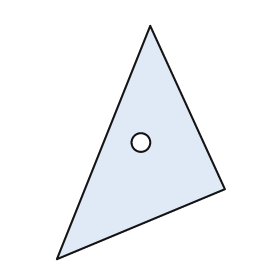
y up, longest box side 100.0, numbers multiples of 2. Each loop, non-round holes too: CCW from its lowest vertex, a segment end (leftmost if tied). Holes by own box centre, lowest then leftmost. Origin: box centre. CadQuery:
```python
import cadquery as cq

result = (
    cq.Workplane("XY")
    .moveTo(-36.0, -50.0)
    .lineTo(36.0, -20.0)
    .lineTo(4.0, 50.0)
    .close()
    .moveTo(0.0, 0.0)
    .circle(4.0)
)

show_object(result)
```